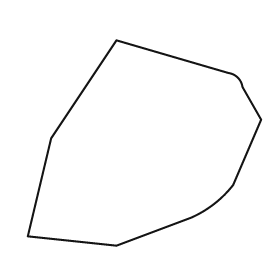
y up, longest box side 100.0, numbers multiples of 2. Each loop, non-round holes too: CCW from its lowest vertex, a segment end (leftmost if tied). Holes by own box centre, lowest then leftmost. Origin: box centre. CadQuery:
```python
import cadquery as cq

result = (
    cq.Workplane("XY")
    .moveTo(-12.0, -44.0)
    .lineTo(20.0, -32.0)
    .threePointArc((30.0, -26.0), (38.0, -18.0))
    .lineTo(50.0, 10.0)
    .lineTo(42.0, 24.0)
    .threePointArc((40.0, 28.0), (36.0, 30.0))
    .lineTo(-12.0, 44.0)
    .lineTo(-40.0, 2.0)
    .lineTo(-50.0, -40.0)
    .close()
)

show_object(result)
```